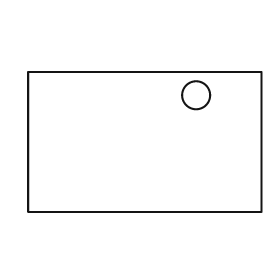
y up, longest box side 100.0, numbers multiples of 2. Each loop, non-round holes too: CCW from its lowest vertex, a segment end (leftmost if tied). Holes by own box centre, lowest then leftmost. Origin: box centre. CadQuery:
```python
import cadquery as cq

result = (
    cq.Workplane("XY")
    .moveTo(-50.0, -30.0)
    .lineTo(50.0, -30.0)
    .lineTo(50.0, 30.0)
    .lineTo(-50.0, 30.0)
    .close()
    .moveTo(22.0, 20.0)
    .circle(6.0)
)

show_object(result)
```